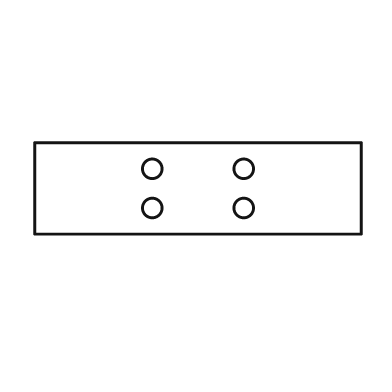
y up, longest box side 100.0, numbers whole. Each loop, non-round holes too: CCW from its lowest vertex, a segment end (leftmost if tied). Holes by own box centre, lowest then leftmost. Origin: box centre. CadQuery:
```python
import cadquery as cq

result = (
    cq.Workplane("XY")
    .moveTo(-50.0, -14.0)
    .lineTo(50.0, -14.0)
    .lineTo(50.0, 14.0)
    .lineTo(-50.0, 14.0)
    .close()
    .moveTo(-14.0, -6.0)
    .circle(3.0)
    .moveTo(14.0, -6.0)
    .circle(3.0)
    .moveTo(-14.0, 6.0)
    .circle(3.0)
    .moveTo(14.0, 6.0)
    .circle(3.0)
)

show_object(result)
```